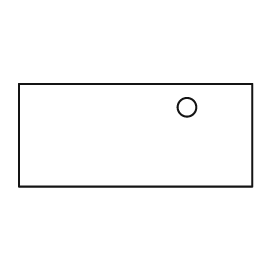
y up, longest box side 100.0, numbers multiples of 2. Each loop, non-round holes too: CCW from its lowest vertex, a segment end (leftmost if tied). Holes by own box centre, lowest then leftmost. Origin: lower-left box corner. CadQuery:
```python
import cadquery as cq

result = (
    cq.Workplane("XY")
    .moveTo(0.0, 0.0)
    .lineTo(100.0, 0.0)
    .lineTo(100.0, 44.0)
    .lineTo(0.0, 44.0)
    .close()
    .moveTo(72.0, 34.0)
    .circle(4.0)
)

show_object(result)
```